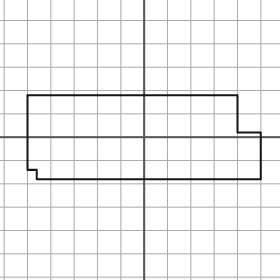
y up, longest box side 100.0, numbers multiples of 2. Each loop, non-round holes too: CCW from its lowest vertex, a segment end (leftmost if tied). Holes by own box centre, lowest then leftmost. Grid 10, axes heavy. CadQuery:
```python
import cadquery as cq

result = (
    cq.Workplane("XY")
    .moveTo(-46.0, -18.0)
    .lineTo(50.0, -18.0)
    .lineTo(50.0, 2.0)
    .lineTo(40.0, 2.0)
    .lineTo(40.0, 18.0)
    .lineTo(-50.0, 18.0)
    .lineTo(-50.0, -14.0)
    .lineTo(-46.0, -14.0)
    .close()
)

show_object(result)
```